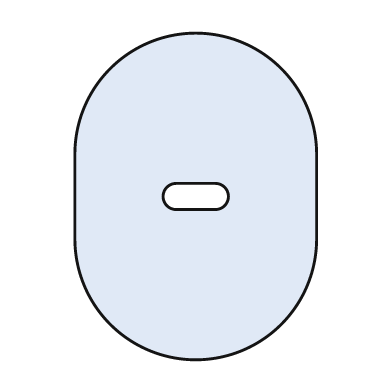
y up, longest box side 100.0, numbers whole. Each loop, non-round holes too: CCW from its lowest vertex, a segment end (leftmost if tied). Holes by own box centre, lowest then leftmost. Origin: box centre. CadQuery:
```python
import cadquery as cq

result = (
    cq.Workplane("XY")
    .moveTo(-37.0, -13.0)
    .threePointArc((0.0, -50.0), (37.0, -13.0))
    .lineTo(37.0, 13.0)
    .threePointArc((0.0, 50.0), (-37.0, 13.0))
    .close()
    .moveTo(-6.0, -4.0)
    .lineTo(6.0, -4.0)
    .threePointArc((10.0, 0.0), (6.0, 4.0))
    .lineTo(-6.0, 4.0)
    .threePointArc((-10.0, 0.0), (-6.0, -4.0))
    .close()
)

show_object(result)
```